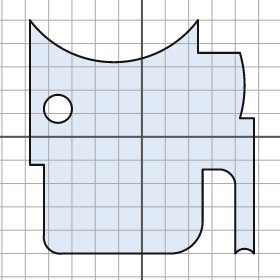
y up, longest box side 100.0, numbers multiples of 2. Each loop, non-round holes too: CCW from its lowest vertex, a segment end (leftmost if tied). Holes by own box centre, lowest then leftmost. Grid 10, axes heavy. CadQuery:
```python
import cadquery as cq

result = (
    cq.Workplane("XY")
    .moveTo(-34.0, -50.0)
    .lineTo(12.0, -50.0)
    .threePointArc((22.0, -46.0), (26.0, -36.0))
    .lineTo(26.0, -14.0)
    .lineTo(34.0, -14.0)
    .threePointArc((38.0, -16.0), (40.0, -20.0))
    .lineTo(40.0, -50.0)
    .threePointArc((44.0, -48.0), (48.0, -50.0))
    .lineTo(48.0, 8.0)
    .lineTo(42.0, 8.0)
    .threePointArc((44.0, 22.0), (42.0, 36.0))
    .lineTo(24.0, 36.0)
    .lineTo(24.0, 50.0)
    .threePointArc((-12.0, 32.0), (-48.0, 50.0))
    .lineTo(-48.0, -12.0)
    .lineTo(-42.0, -12.0)
    .lineTo(-42.0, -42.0)
    .threePointArc((-40.0, -48.0), (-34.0, -50.0))
    .close()
    .moveTo(-36.0, 12.0)
    .circle(6.0)
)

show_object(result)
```